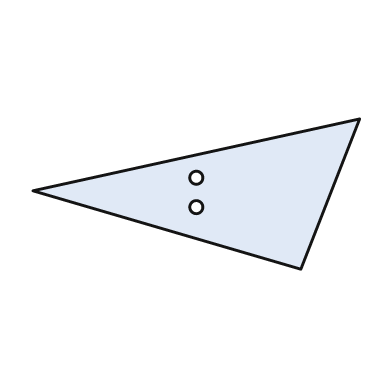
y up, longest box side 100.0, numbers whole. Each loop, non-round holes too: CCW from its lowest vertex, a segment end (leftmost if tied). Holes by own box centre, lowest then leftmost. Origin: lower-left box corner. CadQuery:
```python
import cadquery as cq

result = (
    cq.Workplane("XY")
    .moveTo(82.0, 0.0)
    .lineTo(100.0, 46.0)
    .lineTo(0.0, 24.0)
    .close()
    .moveTo(50.0, 19.0)
    .circle(2.0)
    .moveTo(50.0, 28.0)
    .circle(2.0)
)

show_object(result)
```